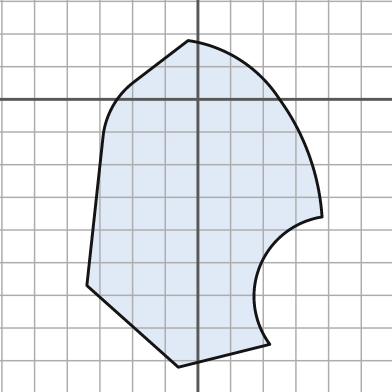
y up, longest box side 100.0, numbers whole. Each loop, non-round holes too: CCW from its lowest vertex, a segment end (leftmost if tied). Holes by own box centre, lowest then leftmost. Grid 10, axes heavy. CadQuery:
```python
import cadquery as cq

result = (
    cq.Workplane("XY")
    .moveTo(-6.0, -82.0)
    .lineTo(22.0, -75.0)
    .threePointArc((19.0, -51.0), (38.0, -36.0))
    .threePointArc((34.0, -17.0), (25.0, 0.0))
    .threePointArc((13.0, 12.0), (-3.0, 18.0))
    .lineTo(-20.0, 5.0)
    .threePointArc((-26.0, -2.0), (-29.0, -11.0))
    .lineTo(-34.0, -57.0)
    .close()
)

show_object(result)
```